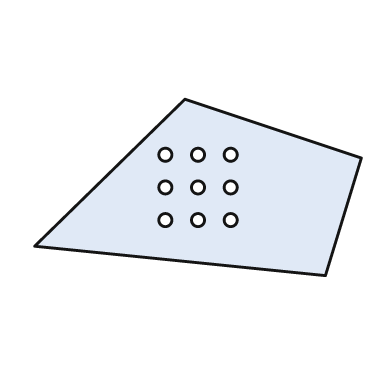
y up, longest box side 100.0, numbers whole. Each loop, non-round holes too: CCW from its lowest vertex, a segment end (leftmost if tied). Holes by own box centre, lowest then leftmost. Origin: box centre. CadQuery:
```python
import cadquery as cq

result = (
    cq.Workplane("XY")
    .moveTo(39.0, -27.0)
    .lineTo(50.0, 9.0)
    .lineTo(-4.0, 27.0)
    .lineTo(-50.0, -18.0)
    .close()
    .moveTo(-10.0, -10.0)
    .circle(2.0)
    .moveTo(0.0, -10.0)
    .circle(2.0)
    .moveTo(10.0, -10.0)
    .circle(2.0)
    .moveTo(-10.0, 0.0)
    .circle(2.0)
    .moveTo(0.0, 0.0)
    .circle(2.0)
    .moveTo(10.0, 0.0)
    .circle(2.0)
    .moveTo(-10.0, 10.0)
    .circle(2.0)
    .moveTo(0.0, 10.0)
    .circle(2.0)
    .moveTo(10.0, 10.0)
    .circle(2.0)
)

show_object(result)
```